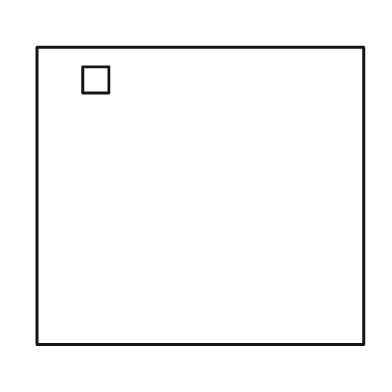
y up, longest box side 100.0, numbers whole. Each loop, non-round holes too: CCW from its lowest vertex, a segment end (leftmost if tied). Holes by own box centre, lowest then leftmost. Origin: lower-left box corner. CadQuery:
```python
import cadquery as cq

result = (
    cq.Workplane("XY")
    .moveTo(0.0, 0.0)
    .lineTo(100.0, 0.0)
    .lineTo(100.0, 91.0)
    .lineTo(0.0, 91.0)
    .close()
    .moveTo(14.0, 77.0)
    .lineTo(22.0, 77.0)
    .lineTo(22.0, 85.0)
    .lineTo(14.0, 85.0)
    .close()
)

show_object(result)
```